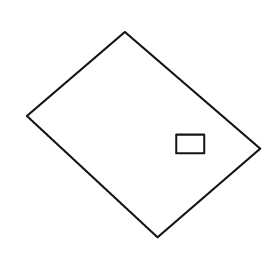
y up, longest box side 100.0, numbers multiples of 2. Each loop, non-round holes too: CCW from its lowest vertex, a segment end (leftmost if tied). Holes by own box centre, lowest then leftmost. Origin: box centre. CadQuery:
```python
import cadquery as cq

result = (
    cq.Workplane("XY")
    .moveTo(6.0, -44.0)
    .lineTo(50.0, -6.0)
    .lineTo(-8.0, 44.0)
    .lineTo(-50.0, 8.0)
    .close()
    .moveTo(14.0, -8.0)
    .lineTo(26.0, -8.0)
    .lineTo(26.0, 0.0)
    .lineTo(14.0, 0.0)
    .close()
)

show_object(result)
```